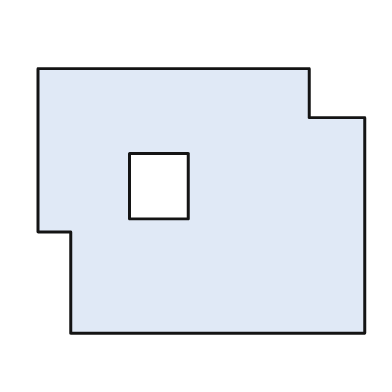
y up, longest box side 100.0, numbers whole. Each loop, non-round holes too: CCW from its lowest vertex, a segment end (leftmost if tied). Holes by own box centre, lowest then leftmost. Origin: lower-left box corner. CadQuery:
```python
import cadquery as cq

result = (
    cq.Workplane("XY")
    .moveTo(10.0, 0.0)
    .lineTo(100.0, 0.0)
    .lineTo(100.0, 66.0)
    .lineTo(83.0, 66.0)
    .lineTo(83.0, 81.0)
    .lineTo(0.0, 81.0)
    .lineTo(0.0, 31.0)
    .lineTo(10.0, 31.0)
    .close()
    .moveTo(28.0, 35.0)
    .lineTo(46.0, 35.0)
    .lineTo(46.0, 55.0)
    .lineTo(28.0, 55.0)
    .close()
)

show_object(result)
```